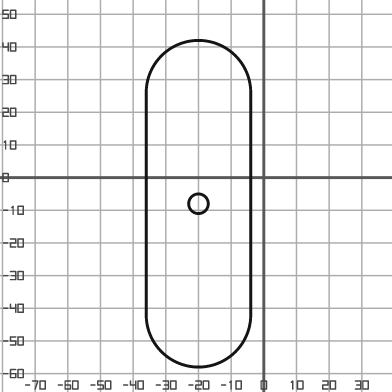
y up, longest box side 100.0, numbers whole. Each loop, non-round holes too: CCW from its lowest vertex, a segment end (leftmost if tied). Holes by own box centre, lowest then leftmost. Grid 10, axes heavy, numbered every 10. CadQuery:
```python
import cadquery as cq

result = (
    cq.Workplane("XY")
    .moveTo(-36.0, -42.0)
    .threePointArc((-20.0, -58.0), (-4.0, -42.0))
    .lineTo(-4.0, 26.0)
    .threePointArc((-20.0, 42.0), (-36.0, 26.0))
    .close()
    .moveTo(-20.0, -8.0)
    .circle(3.0)
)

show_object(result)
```